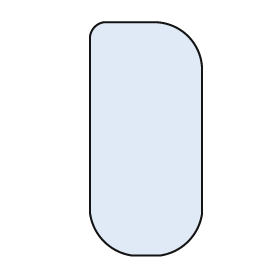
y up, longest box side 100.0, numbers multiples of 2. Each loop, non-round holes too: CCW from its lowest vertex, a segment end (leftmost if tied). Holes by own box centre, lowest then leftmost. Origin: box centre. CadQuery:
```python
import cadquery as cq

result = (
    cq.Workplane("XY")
    .moveTo(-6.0, -50.0)
    .lineTo(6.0, -50.0)
    .threePointArc((18.0, -44.0), (24.0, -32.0))
    .lineTo(24.0, 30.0)
    .threePointArc((18.0, 44.0), (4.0, 50.0))
    .lineTo(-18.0, 50.0)
    .threePointArc((-22.0, 48.0), (-24.0, 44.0))
    .lineTo(-24.0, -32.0)
    .threePointArc((-18.0, -44.0), (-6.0, -50.0))
    .close()
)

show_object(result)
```